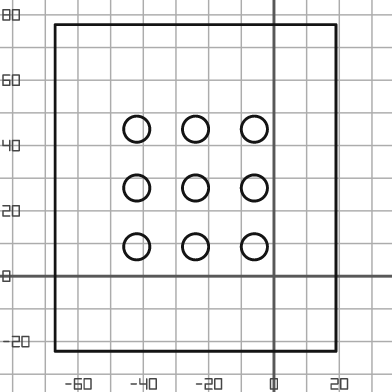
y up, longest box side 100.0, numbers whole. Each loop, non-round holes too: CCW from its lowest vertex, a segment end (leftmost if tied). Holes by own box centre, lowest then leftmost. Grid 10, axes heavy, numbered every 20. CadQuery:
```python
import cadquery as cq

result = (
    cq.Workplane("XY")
    .moveTo(-67.0, -23.0)
    .lineTo(19.0, -23.0)
    .lineTo(19.0, 77.0)
    .lineTo(-67.0, 77.0)
    .close()
    .moveTo(-42.0, 9.0)
    .circle(4.0)
    .moveTo(-24.0, 9.0)
    .circle(4.0)
    .moveTo(-6.0, 9.0)
    .circle(4.0)
    .moveTo(-42.0, 27.0)
    .circle(4.0)
    .moveTo(-24.0, 27.0)
    .circle(4.0)
    .moveTo(-6.0, 27.0)
    .circle(4.0)
    .moveTo(-42.0, 45.0)
    .circle(4.0)
    .moveTo(-24.0, 45.0)
    .circle(4.0)
    .moveTo(-6.0, 45.0)
    .circle(4.0)
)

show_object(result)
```